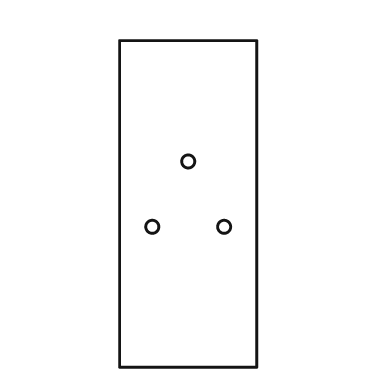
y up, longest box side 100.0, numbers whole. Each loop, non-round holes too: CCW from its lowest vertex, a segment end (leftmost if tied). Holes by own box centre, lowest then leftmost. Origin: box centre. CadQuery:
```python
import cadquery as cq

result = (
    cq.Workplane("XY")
    .moveTo(-21.0, -50.0)
    .lineTo(21.0, -50.0)
    .lineTo(21.0, 50.0)
    .lineTo(-21.0, 50.0)
    .close()
    .moveTo(-11.0, -7.0)
    .circle(2.0)
    .moveTo(11.0, -7.0)
    .circle(2.0)
    .moveTo(0.0, 13.0)
    .circle(2.0)
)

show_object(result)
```